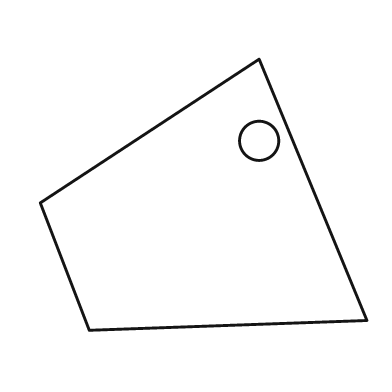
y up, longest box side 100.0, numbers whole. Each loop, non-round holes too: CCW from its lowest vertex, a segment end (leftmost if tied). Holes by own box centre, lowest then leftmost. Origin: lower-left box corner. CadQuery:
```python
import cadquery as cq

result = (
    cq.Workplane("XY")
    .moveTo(15.0, 0.0)
    .lineTo(100.0, 3.0)
    .lineTo(67.0, 83.0)
    .lineTo(0.0, 39.0)
    .close()
    .moveTo(67.0, 58.0)
    .circle(6.0)
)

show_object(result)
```